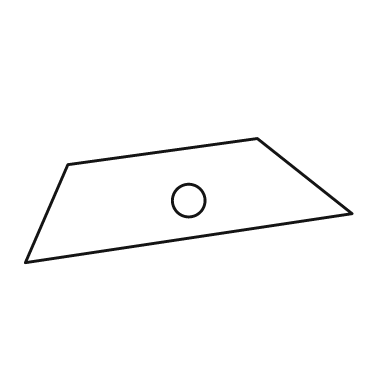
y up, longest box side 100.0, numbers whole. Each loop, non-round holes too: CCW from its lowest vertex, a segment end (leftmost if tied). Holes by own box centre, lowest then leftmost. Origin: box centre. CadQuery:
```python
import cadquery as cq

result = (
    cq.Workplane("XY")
    .moveTo(-50.0, -19.0)
    .lineTo(50.0, -4.0)
    .lineTo(21.0, 19.0)
    .lineTo(-37.0, 11.0)
    .close()
    .moveTo(0.0, 0.0)
    .circle(5.0)
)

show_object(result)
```